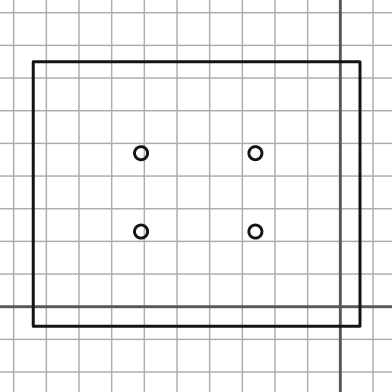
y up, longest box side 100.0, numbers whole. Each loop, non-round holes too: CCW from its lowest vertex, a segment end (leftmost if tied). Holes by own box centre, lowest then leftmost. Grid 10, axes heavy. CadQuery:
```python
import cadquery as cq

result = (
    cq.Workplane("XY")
    .moveTo(-94.0, -6.0)
    .lineTo(6.0, -6.0)
    .lineTo(6.0, 75.0)
    .lineTo(-94.0, 75.0)
    .close()
    .moveTo(-61.0, 23.0)
    .circle(2.0)
    .moveTo(-26.0, 23.0)
    .circle(2.0)
    .moveTo(-61.0, 47.0)
    .circle(2.0)
    .moveTo(-26.0, 47.0)
    .circle(2.0)
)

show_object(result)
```